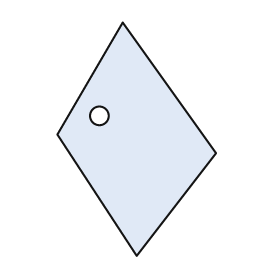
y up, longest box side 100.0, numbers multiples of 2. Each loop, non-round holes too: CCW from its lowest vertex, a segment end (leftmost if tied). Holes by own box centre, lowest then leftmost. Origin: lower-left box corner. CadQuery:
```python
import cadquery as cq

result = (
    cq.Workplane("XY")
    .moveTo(34.0, 0.0)
    .lineTo(68.0, 44.0)
    .lineTo(28.0, 100.0)
    .lineTo(0.0, 52.0)
    .close()
    .moveTo(18.0, 60.0)
    .circle(4.0)
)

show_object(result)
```